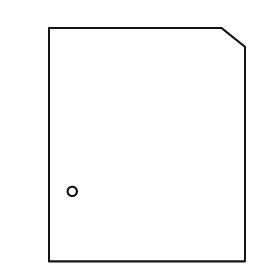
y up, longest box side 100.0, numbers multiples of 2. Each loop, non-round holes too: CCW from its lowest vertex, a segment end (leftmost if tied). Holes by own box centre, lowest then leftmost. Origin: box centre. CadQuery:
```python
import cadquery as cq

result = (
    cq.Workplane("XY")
    .moveTo(-42.0, -50.0)
    .lineTo(42.0, -50.0)
    .lineTo(42.0, 42.0)
    .lineTo(32.0, 50.0)
    .lineTo(-42.0, 50.0)
    .close()
    .moveTo(-32.0, -20.0)
    .circle(2.0)
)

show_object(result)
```